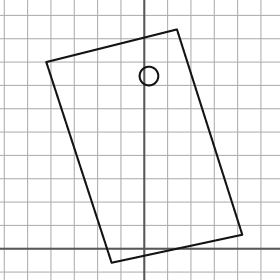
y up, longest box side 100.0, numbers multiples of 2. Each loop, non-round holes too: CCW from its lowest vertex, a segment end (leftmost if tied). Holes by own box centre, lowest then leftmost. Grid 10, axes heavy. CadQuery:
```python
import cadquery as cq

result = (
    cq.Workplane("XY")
    .moveTo(-14.0, -6.0)
    .lineTo(42.0, 6.0)
    .lineTo(14.0, 94.0)
    .lineTo(-42.0, 80.0)
    .close()
    .moveTo(2.0, 74.0)
    .circle(4.0)
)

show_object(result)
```